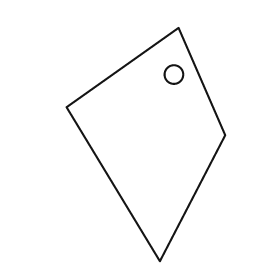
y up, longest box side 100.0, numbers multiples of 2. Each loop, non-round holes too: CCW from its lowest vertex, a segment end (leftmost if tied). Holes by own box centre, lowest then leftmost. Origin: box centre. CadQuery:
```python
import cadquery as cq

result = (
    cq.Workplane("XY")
    .moveTo(6.0, -50.0)
    .lineTo(34.0, 4.0)
    .lineTo(14.0, 50.0)
    .lineTo(-34.0, 16.0)
    .close()
    .moveTo(12.0, 30.0)
    .circle(4.0)
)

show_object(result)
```